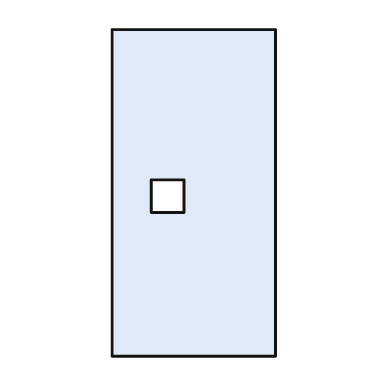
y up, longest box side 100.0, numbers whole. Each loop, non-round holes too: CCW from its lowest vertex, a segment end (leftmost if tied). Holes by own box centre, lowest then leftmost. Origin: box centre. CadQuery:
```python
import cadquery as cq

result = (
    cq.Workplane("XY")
    .moveTo(-25.0, -50.0)
    .lineTo(25.0, -50.0)
    .lineTo(25.0, 50.0)
    .lineTo(-25.0, 50.0)
    .close()
    .moveTo(-13.0, -6.0)
    .lineTo(-3.0, -6.0)
    .lineTo(-3.0, 4.0)
    .lineTo(-13.0, 4.0)
    .close()
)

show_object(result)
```